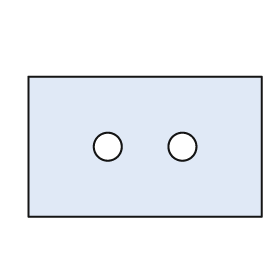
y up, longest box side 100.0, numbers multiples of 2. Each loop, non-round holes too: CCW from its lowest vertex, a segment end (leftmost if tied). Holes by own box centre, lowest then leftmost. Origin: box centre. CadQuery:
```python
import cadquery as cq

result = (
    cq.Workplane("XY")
    .moveTo(-50.0, -30.0)
    .lineTo(50.0, -30.0)
    .lineTo(50.0, 30.0)
    .lineTo(-50.0, 30.0)
    .close()
    .moveTo(-16.0, 0.0)
    .circle(6.0)
    .moveTo(16.0, 0.0)
    .circle(6.0)
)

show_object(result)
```